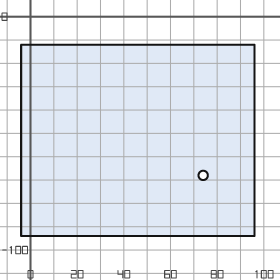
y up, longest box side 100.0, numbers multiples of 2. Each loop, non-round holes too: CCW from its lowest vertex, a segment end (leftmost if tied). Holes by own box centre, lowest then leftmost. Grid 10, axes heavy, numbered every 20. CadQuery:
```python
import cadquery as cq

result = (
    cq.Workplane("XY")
    .moveTo(-4.0, -94.0)
    .lineTo(96.0, -94.0)
    .lineTo(96.0, -12.0)
    .lineTo(-4.0, -12.0)
    .close()
    .moveTo(74.0, -68.0)
    .circle(2.0)
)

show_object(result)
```